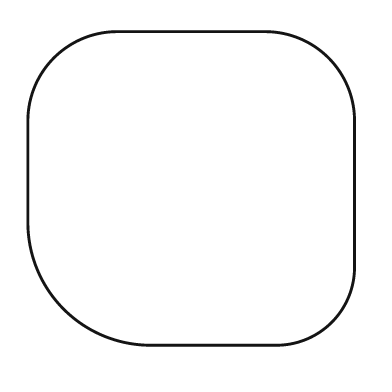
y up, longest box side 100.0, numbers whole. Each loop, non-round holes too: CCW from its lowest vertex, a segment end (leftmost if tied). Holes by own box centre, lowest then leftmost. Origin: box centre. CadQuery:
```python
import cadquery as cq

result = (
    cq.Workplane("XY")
    .moveTo(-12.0, -48.0)
    .lineTo(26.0, -48.0)
    .threePointArc((43.0, -41.0), (50.0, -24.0))
    .lineTo(50.0, 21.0)
    .threePointArc((42.0, 40.0), (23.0, 48.0))
    .lineTo(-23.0, 48.0)
    .threePointArc((-42.0, 40.0), (-50.0, 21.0))
    .lineTo(-50.0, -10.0)
    .threePointArc((-39.0, -37.0), (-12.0, -48.0))
    .close()
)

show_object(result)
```